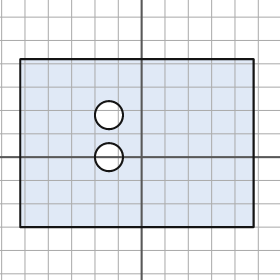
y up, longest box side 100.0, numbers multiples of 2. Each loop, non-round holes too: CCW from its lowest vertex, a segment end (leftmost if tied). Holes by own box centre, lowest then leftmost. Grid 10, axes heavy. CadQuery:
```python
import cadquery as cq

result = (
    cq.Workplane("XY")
    .moveTo(-52.0, -30.0)
    .lineTo(48.0, -30.0)
    .lineTo(48.0, 42.0)
    .lineTo(-52.0, 42.0)
    .close()
    .moveTo(-14.0, 0.0)
    .circle(6.0)
    .moveTo(-14.0, 18.0)
    .circle(6.0)
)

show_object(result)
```